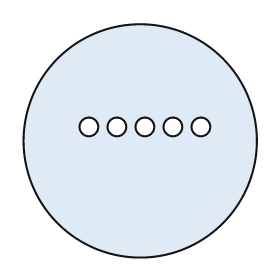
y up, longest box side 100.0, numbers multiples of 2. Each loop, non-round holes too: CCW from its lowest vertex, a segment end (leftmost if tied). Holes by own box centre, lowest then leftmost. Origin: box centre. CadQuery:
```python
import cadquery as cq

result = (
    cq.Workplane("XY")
    .moveTo(0.0, 0.0)
    .circle(50.0)
    .moveTo(-22.0, 6.0)
    .circle(4.0)
    .moveTo(-10.0, 6.0)
    .circle(4.0)
    .moveTo(2.0, 6.0)
    .circle(4.0)
    .moveTo(14.0, 6.0)
    .circle(4.0)
    .moveTo(26.0, 6.0)
    .circle(4.0)
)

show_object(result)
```